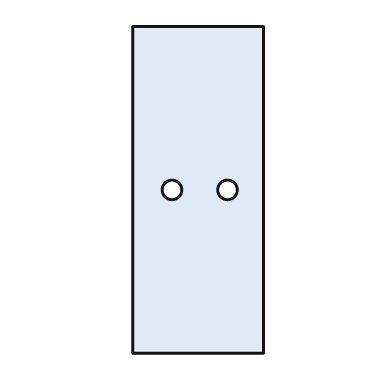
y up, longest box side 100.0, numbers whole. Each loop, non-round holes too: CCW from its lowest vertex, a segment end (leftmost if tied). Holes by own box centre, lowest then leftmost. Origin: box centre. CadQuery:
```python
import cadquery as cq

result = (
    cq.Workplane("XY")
    .moveTo(-20.0, -50.0)
    .lineTo(20.0, -50.0)
    .lineTo(20.0, 50.0)
    .lineTo(-20.0, 50.0)
    .close()
    .moveTo(-8.0, 0.0)
    .circle(3.0)
    .moveTo(9.0, 0.0)
    .circle(3.0)
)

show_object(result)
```